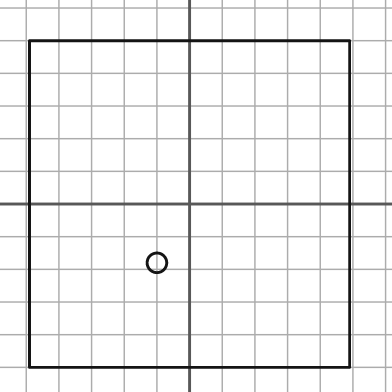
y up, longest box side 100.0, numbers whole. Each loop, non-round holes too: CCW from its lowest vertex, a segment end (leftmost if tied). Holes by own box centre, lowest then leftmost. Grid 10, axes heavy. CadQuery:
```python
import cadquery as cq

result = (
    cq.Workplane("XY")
    .moveTo(-49.0, -50.0)
    .lineTo(49.0, -50.0)
    .lineTo(49.0, 50.0)
    .lineTo(-49.0, 50.0)
    .close()
    .moveTo(-10.0, -18.0)
    .circle(3.0)
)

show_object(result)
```